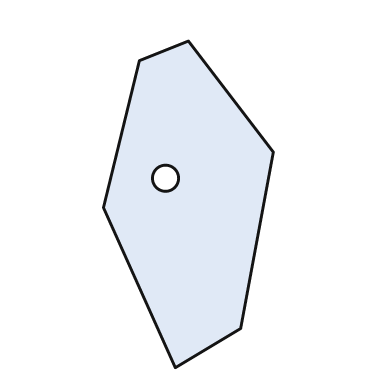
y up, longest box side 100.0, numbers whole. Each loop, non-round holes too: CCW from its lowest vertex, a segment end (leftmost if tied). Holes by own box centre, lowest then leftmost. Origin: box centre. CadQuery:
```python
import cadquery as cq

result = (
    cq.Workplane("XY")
    .moveTo(-4.0, -50.0)
    .lineTo(16.0, -38.0)
    .lineTo(26.0, 16.0)
    .lineTo(0.0, 50.0)
    .lineTo(-15.0, 44.0)
    .lineTo(-26.0, -1.0)
    .close()
    .moveTo(-7.0, 8.0)
    .circle(4.0)
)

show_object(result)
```